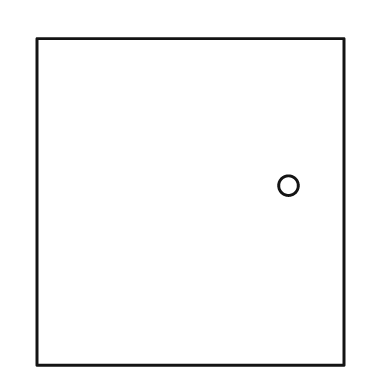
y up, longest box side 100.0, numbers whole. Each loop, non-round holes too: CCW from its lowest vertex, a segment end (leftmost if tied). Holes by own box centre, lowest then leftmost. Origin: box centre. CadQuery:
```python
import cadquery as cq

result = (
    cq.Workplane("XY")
    .moveTo(-47.0, -50.0)
    .lineTo(47.0, -50.0)
    .lineTo(47.0, 50.0)
    .lineTo(-47.0, 50.0)
    .close()
    .moveTo(30.0, 5.0)
    .circle(3.0)
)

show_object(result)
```